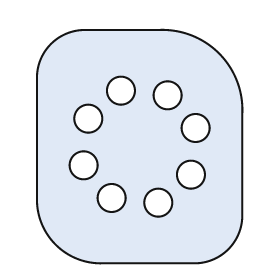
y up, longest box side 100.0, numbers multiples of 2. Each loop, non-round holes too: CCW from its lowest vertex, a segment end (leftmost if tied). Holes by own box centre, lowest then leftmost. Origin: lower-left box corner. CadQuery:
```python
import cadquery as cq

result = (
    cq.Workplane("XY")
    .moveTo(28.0, 0.0)
    .lineTo(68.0, 0.0)
    .threePointArc((82.0, 6.0), (88.0, 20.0))
    .lineTo(88.0, 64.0)
    .threePointArc((78.0, 90.0), (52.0, 100.0))
    .lineTo(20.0, 100.0)
    .threePointArc((6.0, 94.0), (0.0, 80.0))
    .lineTo(0.0, 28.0)
    .threePointArc((8.0, 8.0), (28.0, 0.0))
    .close()
    .moveTo(52.0, 26.0)
    .circle(6.0)
    .moveTo(32.0, 28.0)
    .circle(6.0)
    .moveTo(66.0, 38.0)
    .circle(6.0)
    .moveTo(20.0, 42.0)
    .circle(6.0)
    .moveTo(68.0, 58.0)
    .circle(6.0)
    .moveTo(22.0, 62.0)
    .circle(6.0)
    .moveTo(56.0, 72.0)
    .circle(6.0)
    .moveTo(36.0, 74.0)
    .circle(6.0)
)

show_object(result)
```